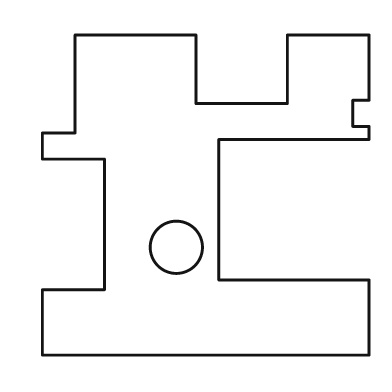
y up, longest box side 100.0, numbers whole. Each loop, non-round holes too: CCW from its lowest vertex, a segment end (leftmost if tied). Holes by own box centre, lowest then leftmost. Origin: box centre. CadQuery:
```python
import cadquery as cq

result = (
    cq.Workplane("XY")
    .moveTo(-50.0, -49.0)
    .lineTo(50.0, -49.0)
    .lineTo(50.0, -26.0)
    .lineTo(4.0, -26.0)
    .lineTo(4.0, 17.0)
    .lineTo(50.0, 17.0)
    .lineTo(50.0, 21.0)
    .lineTo(45.0, 21.0)
    .lineTo(45.0, 29.0)
    .lineTo(50.0, 29.0)
    .lineTo(50.0, 49.0)
    .lineTo(25.0, 49.0)
    .lineTo(25.0, 28.0)
    .lineTo(-3.0, 28.0)
    .lineTo(-3.0, 49.0)
    .lineTo(-40.0, 49.0)
    .lineTo(-40.0, 19.0)
    .lineTo(-50.0, 19.0)
    .lineTo(-50.0, 11.0)
    .lineTo(-31.0, 11.0)
    .lineTo(-31.0, -29.0)
    .lineTo(-50.0, -29.0)
    .close()
    .moveTo(-9.0, -16.0)
    .circle(8.0)
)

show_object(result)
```